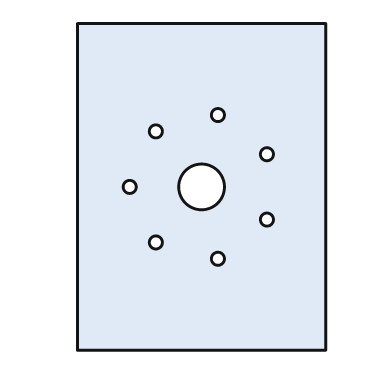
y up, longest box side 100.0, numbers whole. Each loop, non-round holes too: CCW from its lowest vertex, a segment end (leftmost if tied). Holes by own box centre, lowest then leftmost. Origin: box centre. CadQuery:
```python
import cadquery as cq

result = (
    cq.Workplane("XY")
    .moveTo(-38.0, -50.0)
    .lineTo(38.0, -50.0)
    .lineTo(38.0, 50.0)
    .lineTo(-38.0, 50.0)
    .close()
    .moveTo(5.0, -22.0)
    .circle(2.0)
    .moveTo(-14.0, -17.0)
    .circle(2.0)
    .moveTo(20.0, -10.0)
    .circle(2.0)
    .moveTo(-22.0, 0.0)
    .circle(2.0)
    .moveTo(0.0, 0.0)
    .circle(7.0)
    .moveTo(20.0, 10.0)
    .circle(2.0)
    .moveTo(-14.0, 17.0)
    .circle(2.0)
    .moveTo(5.0, 22.0)
    .circle(2.0)
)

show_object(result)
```